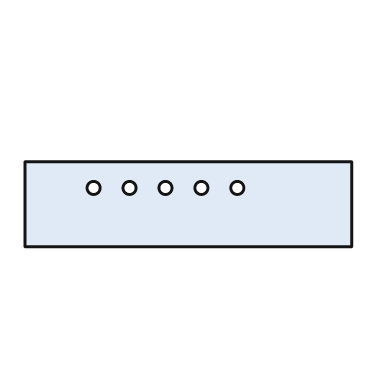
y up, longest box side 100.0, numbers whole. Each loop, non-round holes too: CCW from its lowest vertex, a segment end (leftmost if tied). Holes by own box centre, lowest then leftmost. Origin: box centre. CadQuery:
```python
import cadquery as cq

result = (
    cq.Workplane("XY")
    .moveTo(-50.0, -13.0)
    .lineTo(50.0, -13.0)
    .lineTo(50.0, 13.0)
    .lineTo(-50.0, 13.0)
    .close()
    .moveTo(-29.0, 5.0)
    .circle(2.0)
    .moveTo(-18.0, 5.0)
    .circle(2.0)
    .moveTo(-7.0, 5.0)
    .circle(2.0)
    .moveTo(4.0, 5.0)
    .circle(2.0)
    .moveTo(15.0, 5.0)
    .circle(2.0)
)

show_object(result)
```